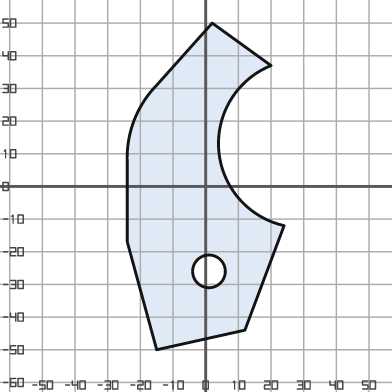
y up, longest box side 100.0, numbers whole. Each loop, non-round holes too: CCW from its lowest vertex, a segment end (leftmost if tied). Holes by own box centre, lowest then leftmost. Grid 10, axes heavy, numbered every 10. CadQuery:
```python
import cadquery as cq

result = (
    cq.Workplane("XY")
    .moveTo(-15.0, -50.0)
    .lineTo(12.0, -44.0)
    .lineTo(24.0, -12.0)
    .threePointArc((4.0, 11.0), (20.0, 37.0))
    .lineTo(2.0, 50.0)
    .lineTo(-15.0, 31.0)
    .threePointArc((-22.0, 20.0), (-24.0, 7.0))
    .lineTo(-24.0, -17.0)
    .close()
    .moveTo(1.0, -26.0)
    .circle(5.0)
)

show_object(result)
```